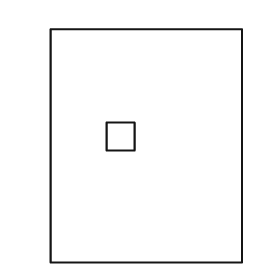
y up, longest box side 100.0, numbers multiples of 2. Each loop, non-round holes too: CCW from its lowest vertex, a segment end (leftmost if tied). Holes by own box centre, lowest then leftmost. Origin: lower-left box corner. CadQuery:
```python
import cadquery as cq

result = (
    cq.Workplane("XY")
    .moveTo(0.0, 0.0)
    .lineTo(82.0, 0.0)
    .lineTo(82.0, 100.0)
    .lineTo(0.0, 100.0)
    .close()
    .moveTo(24.0, 48.0)
    .lineTo(36.0, 48.0)
    .lineTo(36.0, 60.0)
    .lineTo(24.0, 60.0)
    .close()
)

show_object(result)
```